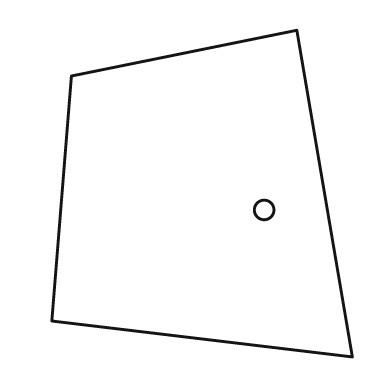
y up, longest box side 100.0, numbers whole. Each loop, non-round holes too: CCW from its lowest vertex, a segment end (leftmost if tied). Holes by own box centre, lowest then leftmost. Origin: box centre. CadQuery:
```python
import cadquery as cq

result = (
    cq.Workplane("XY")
    .moveTo(46.0, -50.0)
    .lineTo(29.0, 50.0)
    .lineTo(-40.0, 36.0)
    .lineTo(-46.0, -39.0)
    .close()
    .moveTo(19.0, -5.0)
    .circle(3.0)
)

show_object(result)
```